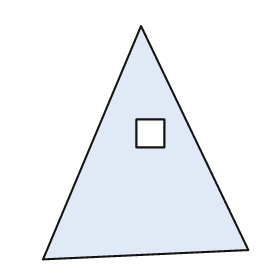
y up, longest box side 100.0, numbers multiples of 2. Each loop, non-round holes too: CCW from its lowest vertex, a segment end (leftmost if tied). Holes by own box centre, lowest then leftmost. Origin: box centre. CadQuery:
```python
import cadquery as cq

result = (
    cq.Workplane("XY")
    .moveTo(-44.0, -50.0)
    .lineTo(44.0, -46.0)
    .lineTo(-2.0, 50.0)
    .close()
    .moveTo(-4.0, -2.0)
    .lineTo(8.0, -2.0)
    .lineTo(8.0, 10.0)
    .lineTo(-4.0, 10.0)
    .close()
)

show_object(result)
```